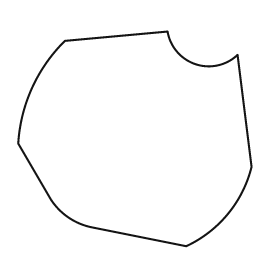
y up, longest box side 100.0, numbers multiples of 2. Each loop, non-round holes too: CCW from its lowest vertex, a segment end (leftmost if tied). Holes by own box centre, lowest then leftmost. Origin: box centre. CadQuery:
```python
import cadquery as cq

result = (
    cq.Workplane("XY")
    .moveTo(22.0, -46.0)
    .threePointArc((40.0, -32.0), (50.0, -12.0))
    .lineTo(44.0, 36.0)
    .threePointArc((26.0, 32.0), (14.0, 46.0))
    .lineTo(-30.0, 42.0)
    .threePointArc((-44.0, 22.0), (-50.0, -2.0))
    .lineTo(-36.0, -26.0)
    .threePointArc((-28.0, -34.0), (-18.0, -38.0))
    .close()
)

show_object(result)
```